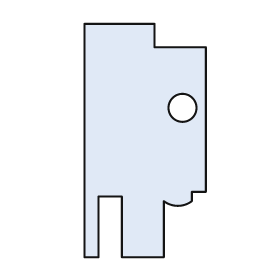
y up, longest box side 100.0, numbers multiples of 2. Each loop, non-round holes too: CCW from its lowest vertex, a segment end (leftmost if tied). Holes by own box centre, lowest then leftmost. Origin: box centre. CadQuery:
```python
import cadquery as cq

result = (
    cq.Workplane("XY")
    .moveTo(-26.0, -50.0)
    .lineTo(-20.0, -50.0)
    .lineTo(-20.0, -24.0)
    .lineTo(-10.0, -24.0)
    .lineTo(-10.0, -50.0)
    .lineTo(8.0, -50.0)
    .lineTo(8.0, -26.0)
    .threePointArc((14.0, -28.0), (20.0, -26.0))
    .lineTo(20.0, -22.0)
    .lineTo(26.0, -22.0)
    .lineTo(26.0, 40.0)
    .lineTo(4.0, 40.0)
    .lineTo(4.0, 50.0)
    .lineTo(-26.0, 50.0)
    .close()
    .moveTo(16.0, 14.0)
    .circle(6.0)
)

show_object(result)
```